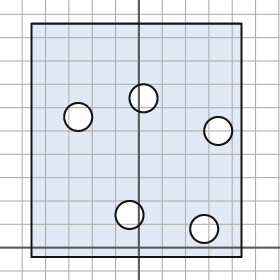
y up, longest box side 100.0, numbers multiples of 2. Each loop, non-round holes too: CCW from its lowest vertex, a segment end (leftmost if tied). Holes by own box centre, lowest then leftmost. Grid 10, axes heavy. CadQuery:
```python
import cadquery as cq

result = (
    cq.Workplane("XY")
    .moveTo(-46.0, -4.0)
    .lineTo(44.0, -4.0)
    .lineTo(44.0, 96.0)
    .lineTo(-46.0, 96.0)
    .close()
    .moveTo(28.0, 8.0)
    .circle(6.0)
    .moveTo(-4.0, 14.0)
    .circle(6.0)
    .moveTo(34.0, 50.0)
    .circle(6.0)
    .moveTo(-26.0, 56.0)
    .circle(6.0)
    .moveTo(2.0, 64.0)
    .circle(6.0)
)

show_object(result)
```